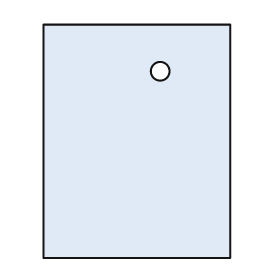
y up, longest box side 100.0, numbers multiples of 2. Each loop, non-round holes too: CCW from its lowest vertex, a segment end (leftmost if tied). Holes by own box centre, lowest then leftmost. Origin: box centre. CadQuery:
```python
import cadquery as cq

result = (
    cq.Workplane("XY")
    .moveTo(-40.0, -50.0)
    .lineTo(40.0, -50.0)
    .lineTo(40.0, 50.0)
    .lineTo(-40.0, 50.0)
    .close()
    .moveTo(10.0, 30.0)
    .circle(4.0)
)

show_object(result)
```